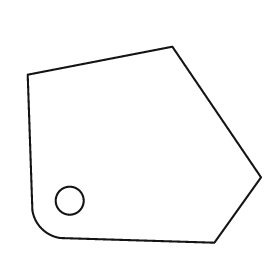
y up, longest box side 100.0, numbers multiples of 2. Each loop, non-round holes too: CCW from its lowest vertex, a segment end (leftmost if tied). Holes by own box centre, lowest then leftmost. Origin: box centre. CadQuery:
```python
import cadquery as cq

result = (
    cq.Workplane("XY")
    .moveTo(30.0, -42.0)
    .lineTo(50.0, -14.0)
    .lineTo(12.0, 42.0)
    .lineTo(-50.0, 30.0)
    .lineTo(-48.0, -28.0)
    .threePointArc((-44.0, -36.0), (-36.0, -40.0))
    .close()
    .moveTo(-32.0, -24.0)
    .circle(6.0)
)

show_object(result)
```